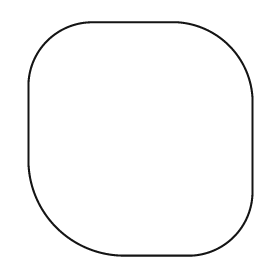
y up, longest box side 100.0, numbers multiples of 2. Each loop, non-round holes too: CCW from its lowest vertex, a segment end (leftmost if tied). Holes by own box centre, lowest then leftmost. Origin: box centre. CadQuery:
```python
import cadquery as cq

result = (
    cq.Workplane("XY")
    .moveTo(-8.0, -50.0)
    .lineTo(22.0, -50.0)
    .threePointArc((40.0, -42.0), (48.0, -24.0))
    .lineTo(48.0, 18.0)
    .threePointArc((38.0, 40.0), (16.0, 50.0))
    .lineTo(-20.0, 50.0)
    .threePointArc((-40.0, 42.0), (-48.0, 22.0))
    .lineTo(-48.0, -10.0)
    .threePointArc((-36.0, -38.0), (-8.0, -50.0))
    .close()
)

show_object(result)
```